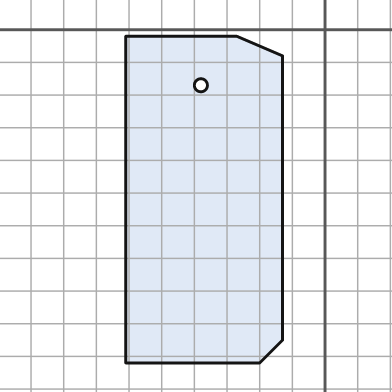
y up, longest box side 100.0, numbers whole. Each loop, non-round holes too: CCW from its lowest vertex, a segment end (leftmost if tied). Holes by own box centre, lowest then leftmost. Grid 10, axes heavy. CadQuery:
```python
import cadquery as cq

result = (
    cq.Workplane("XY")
    .moveTo(-61.0, -102.0)
    .lineTo(-20.0, -102.0)
    .lineTo(-13.0, -95.0)
    .lineTo(-13.0, -8.0)
    .lineTo(-27.0, -2.0)
    .lineTo(-61.0, -2.0)
    .close()
    .moveTo(-38.0, -17.0)
    .circle(2.0)
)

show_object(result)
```